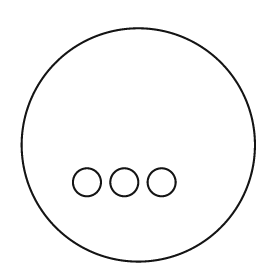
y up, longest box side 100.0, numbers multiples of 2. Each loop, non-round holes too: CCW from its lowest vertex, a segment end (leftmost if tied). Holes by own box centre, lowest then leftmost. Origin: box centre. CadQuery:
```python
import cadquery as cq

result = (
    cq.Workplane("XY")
    .moveTo(0.0, 0.0)
    .circle(50.0)
    .moveTo(-22.0, -16.0)
    .circle(6.0)
    .moveTo(-6.0, -16.0)
    .circle(6.0)
    .moveTo(10.0, -16.0)
    .circle(6.0)
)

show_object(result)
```